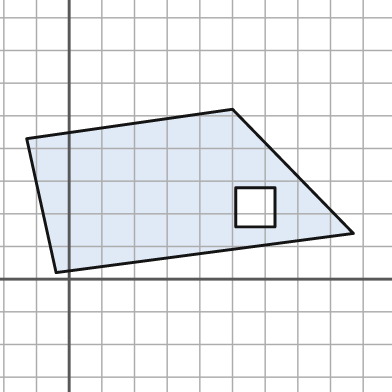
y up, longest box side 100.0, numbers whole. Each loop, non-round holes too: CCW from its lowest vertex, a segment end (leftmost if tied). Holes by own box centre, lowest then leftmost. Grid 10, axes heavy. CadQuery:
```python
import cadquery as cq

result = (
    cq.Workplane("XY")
    .moveTo(-4.0, 2.0)
    .lineTo(87.0, 14.0)
    .lineTo(50.0, 52.0)
    .lineTo(-13.0, 43.0)
    .close()
    .moveTo(51.0, 16.0)
    .lineTo(63.0, 16.0)
    .lineTo(63.0, 28.0)
    .lineTo(51.0, 28.0)
    .close()
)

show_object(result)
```